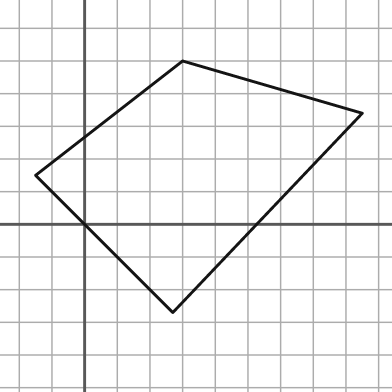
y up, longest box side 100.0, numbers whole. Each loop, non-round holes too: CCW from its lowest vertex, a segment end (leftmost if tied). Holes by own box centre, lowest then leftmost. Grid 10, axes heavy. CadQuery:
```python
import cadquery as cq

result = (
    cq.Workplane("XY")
    .moveTo(27.0, -27.0)
    .lineTo(85.0, 34.0)
    .lineTo(30.0, 50.0)
    .lineTo(-15.0, 15.0)
    .close()
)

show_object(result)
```